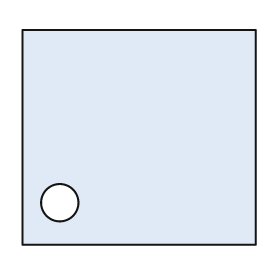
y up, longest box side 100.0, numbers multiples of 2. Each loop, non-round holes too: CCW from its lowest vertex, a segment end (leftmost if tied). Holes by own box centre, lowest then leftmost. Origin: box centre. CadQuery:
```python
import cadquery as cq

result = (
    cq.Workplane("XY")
    .moveTo(-50.0, -46.0)
    .lineTo(50.0, -46.0)
    .lineTo(50.0, 46.0)
    .lineTo(-50.0, 46.0)
    .close()
    .moveTo(-34.0, -28.0)
    .circle(8.0)
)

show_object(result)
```